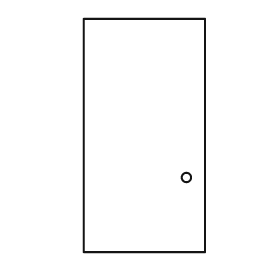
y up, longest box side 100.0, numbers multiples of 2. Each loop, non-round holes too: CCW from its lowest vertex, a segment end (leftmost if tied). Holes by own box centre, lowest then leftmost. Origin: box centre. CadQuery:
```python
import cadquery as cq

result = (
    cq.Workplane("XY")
    .moveTo(-26.0, -50.0)
    .lineTo(26.0, -50.0)
    .lineTo(26.0, 50.0)
    .lineTo(-26.0, 50.0)
    .close()
    .moveTo(18.0, -18.0)
    .circle(2.0)
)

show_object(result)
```